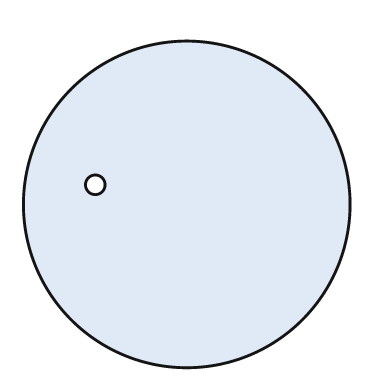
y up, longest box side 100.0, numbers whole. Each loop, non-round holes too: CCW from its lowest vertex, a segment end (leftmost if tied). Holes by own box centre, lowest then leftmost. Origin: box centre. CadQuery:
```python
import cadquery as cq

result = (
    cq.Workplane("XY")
    .moveTo(0.0, 0.0)
    .circle(50.0)
    .moveTo(-28.0, 6.0)
    .circle(3.0)
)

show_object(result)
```